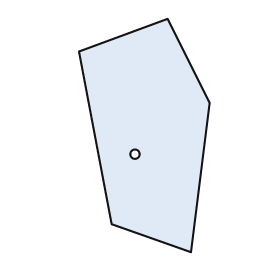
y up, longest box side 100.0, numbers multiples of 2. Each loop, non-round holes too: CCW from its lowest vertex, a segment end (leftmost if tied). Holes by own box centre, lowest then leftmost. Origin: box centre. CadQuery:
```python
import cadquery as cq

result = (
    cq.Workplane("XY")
    .moveTo(20.0, -50.0)
    .lineTo(28.0, 14.0)
    .lineTo(10.0, 50.0)
    .lineTo(-28.0, 36.0)
    .lineTo(-14.0, -38.0)
    .close()
    .moveTo(-4.0, -8.0)
    .circle(2.0)
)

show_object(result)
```